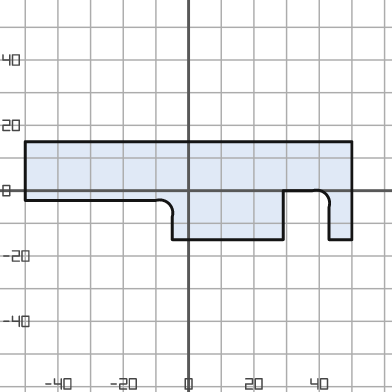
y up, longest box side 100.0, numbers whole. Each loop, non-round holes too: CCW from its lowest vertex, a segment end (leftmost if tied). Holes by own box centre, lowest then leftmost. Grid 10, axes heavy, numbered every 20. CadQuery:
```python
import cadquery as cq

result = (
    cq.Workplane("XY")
    .moveTo(-5.0, -15.0)
    .lineTo(29.0, -15.0)
    .lineTo(29.0, 0.0)
    .lineTo(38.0, 0.0)
    .threePointArc((42.0, -1.0), (43.0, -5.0))
    .lineTo(43.0, -15.0)
    .lineTo(50.0, -15.0)
    .lineTo(50.0, 15.0)
    .lineTo(-50.0, 15.0)
    .lineTo(-50.0, -3.0)
    .lineTo(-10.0, -3.0)
    .threePointArc((-6.0, -4.0), (-5.0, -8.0))
    .close()
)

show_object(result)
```